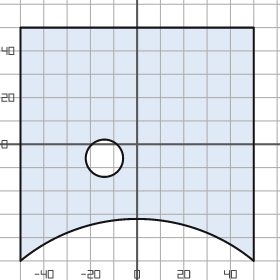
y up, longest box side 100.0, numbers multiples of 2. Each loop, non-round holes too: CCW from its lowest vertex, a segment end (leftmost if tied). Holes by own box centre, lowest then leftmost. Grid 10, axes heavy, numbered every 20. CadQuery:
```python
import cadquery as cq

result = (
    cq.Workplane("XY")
    .moveTo(-50.0, -50.0)
    .threePointArc((0.0, -32.0), (50.0, -50.0))
    .lineTo(50.0, 50.0)
    .lineTo(-50.0, 50.0)
    .close()
    .moveTo(-14.0, -6.0)
    .circle(8.0)
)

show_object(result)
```